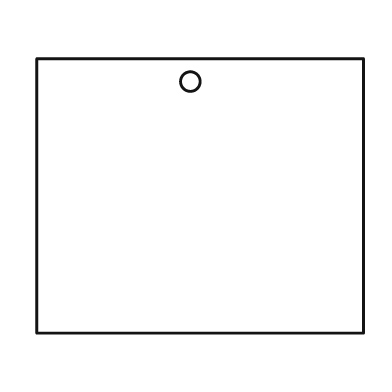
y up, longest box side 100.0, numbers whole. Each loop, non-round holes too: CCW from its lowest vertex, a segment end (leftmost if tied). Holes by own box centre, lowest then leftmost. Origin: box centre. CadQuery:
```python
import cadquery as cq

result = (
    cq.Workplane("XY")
    .moveTo(-50.0, -42.0)
    .lineTo(50.0, -42.0)
    .lineTo(50.0, 42.0)
    .lineTo(-50.0, 42.0)
    .close()
    .moveTo(-3.0, 35.0)
    .circle(3.0)
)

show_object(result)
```